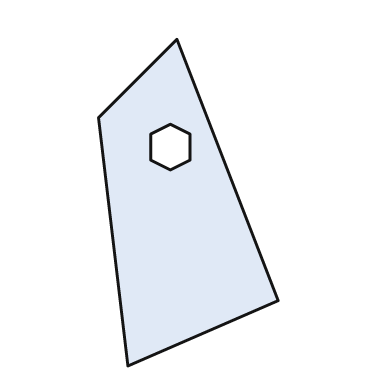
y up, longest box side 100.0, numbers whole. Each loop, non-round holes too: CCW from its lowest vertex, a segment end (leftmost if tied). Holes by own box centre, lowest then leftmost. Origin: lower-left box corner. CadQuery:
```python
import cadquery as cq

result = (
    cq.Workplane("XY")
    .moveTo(9.0, 0.0)
    .lineTo(55.0, 20.0)
    .lineTo(24.0, 100.0)
    .lineTo(0.0, 76.0)
    .close()
    .moveTo(22.0, 60.0)
    .lineTo(28.0, 63.0)
    .lineTo(28.0, 71.0)
    .lineTo(22.0, 74.0)
    .lineTo(16.0, 71.0)
    .lineTo(16.0, 63.0)
    .close()
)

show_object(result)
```